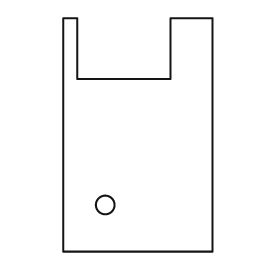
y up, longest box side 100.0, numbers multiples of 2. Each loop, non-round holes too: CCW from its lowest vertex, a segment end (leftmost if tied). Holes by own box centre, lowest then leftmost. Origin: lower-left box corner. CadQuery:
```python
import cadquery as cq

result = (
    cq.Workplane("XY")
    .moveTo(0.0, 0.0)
    .lineTo(64.0, 0.0)
    .lineTo(64.0, 100.0)
    .lineTo(46.0, 100.0)
    .lineTo(46.0, 74.0)
    .lineTo(6.0, 74.0)
    .lineTo(6.0, 100.0)
    .lineTo(0.0, 100.0)
    .close()
    .moveTo(18.0, 20.0)
    .circle(4.0)
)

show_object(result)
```